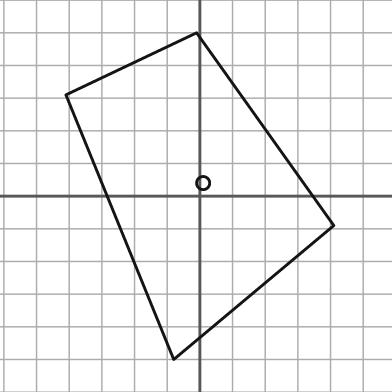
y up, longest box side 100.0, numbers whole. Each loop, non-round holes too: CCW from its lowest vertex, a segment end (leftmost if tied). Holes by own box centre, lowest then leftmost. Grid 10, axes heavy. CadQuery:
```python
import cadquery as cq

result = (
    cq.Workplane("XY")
    .moveTo(-8.0, -50.0)
    .lineTo(41.0, -9.0)
    .lineTo(-1.0, 50.0)
    .lineTo(-41.0, 31.0)
    .close()
    .moveTo(1.0, 4.0)
    .circle(2.0)
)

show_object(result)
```